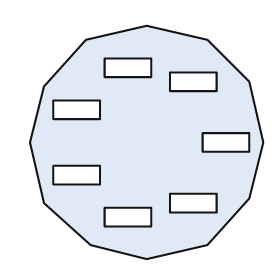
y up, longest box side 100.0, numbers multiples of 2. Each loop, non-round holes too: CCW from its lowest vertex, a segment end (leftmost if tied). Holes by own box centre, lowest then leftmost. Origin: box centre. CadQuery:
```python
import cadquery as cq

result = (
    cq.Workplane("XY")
    .moveTo(0.0, -50.0)
    .lineTo(26.0, -44.0)
    .lineTo(44.0, -24.0)
    .lineTo(50.0, 0.0)
    .lineTo(44.0, 26.0)
    .lineTo(26.0, 44.0)
    .lineTo(0.0, 50.0)
    .lineTo(-26.0, 44.0)
    .lineTo(-44.0, 24.0)
    .lineTo(-50.0, 0.0)
    .lineTo(-44.0, -26.0)
    .lineTo(-24.0, -44.0)
    .close()
    .moveTo(-18.0, -36.0)
    .lineTo(2.0, -36.0)
    .lineTo(2.0, -28.0)
    .lineTo(-18.0, -28.0)
    .close()
    .moveTo(10.0, -30.0)
    .lineTo(30.0, -30.0)
    .lineTo(30.0, -22.0)
    .lineTo(10.0, -22.0)
    .close()
    .moveTo(-40.0, -18.0)
    .lineTo(-20.0, -18.0)
    .lineTo(-20.0, -10.0)
    .lineTo(-40.0, -10.0)
    .close()
    .moveTo(24.0, -4.0)
    .lineTo(44.0, -4.0)
    .lineTo(44.0, 4.0)
    .lineTo(24.0, 4.0)
    .close()
    .moveTo(-40.0, 10.0)
    .lineTo(-20.0, 10.0)
    .lineTo(-20.0, 18.0)
    .lineTo(-40.0, 18.0)
    .close()
    .moveTo(10.0, 22.0)
    .lineTo(30.0, 22.0)
    .lineTo(30.0, 30.0)
    .lineTo(10.0, 30.0)
    .close()
    .moveTo(-18.0, 28.0)
    .lineTo(2.0, 28.0)
    .lineTo(2.0, 36.0)
    .lineTo(-18.0, 36.0)
    .close()
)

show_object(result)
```